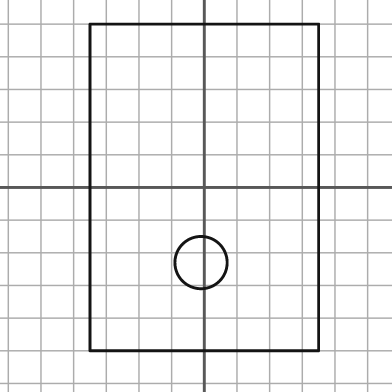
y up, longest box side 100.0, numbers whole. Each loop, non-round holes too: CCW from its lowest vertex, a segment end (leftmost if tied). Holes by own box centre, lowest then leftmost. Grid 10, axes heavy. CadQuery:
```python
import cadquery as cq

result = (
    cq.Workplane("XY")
    .moveTo(-35.0, -50.0)
    .lineTo(35.0, -50.0)
    .lineTo(35.0, 50.0)
    .lineTo(-35.0, 50.0)
    .close()
    .moveTo(-1.0, -23.0)
    .circle(8.0)
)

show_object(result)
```